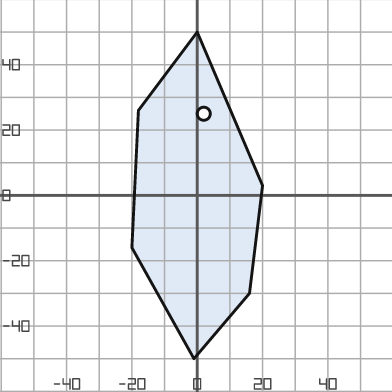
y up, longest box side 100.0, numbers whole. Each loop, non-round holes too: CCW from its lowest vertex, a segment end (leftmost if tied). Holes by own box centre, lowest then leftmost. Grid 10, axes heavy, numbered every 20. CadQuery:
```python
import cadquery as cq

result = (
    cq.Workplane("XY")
    .moveTo(-1.0, -50.0)
    .lineTo(16.0, -30.0)
    .lineTo(20.0, 3.0)
    .lineTo(0.0, 50.0)
    .lineTo(-18.0, 26.0)
    .lineTo(-20.0, -16.0)
    .close()
    .moveTo(2.0, 25.0)
    .circle(2.0)
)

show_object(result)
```